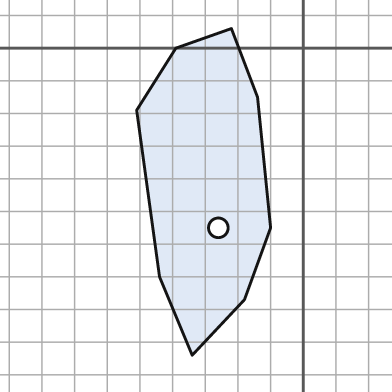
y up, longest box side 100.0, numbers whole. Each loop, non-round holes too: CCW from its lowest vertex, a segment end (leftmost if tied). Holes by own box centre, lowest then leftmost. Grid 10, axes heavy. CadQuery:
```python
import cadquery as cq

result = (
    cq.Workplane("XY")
    .moveTo(-34.0, -94.0)
    .lineTo(-18.0, -77.0)
    .lineTo(-10.0, -55.0)
    .lineTo(-14.0, -15.0)
    .lineTo(-22.0, 6.0)
    .lineTo(-39.0, 0.0)
    .lineTo(-51.0, -19.0)
    .lineTo(-44.0, -70.0)
    .close()
    .moveTo(-26.0, -55.0)
    .circle(3.0)
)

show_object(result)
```